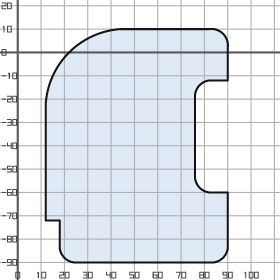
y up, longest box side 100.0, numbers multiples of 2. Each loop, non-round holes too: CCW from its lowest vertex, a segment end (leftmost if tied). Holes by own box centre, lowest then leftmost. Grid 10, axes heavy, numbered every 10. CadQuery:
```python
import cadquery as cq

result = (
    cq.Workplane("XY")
    .moveTo(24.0, -90.0)
    .lineTo(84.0, -90.0)
    .threePointArc((88.0, -88.0), (90.0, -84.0))
    .lineTo(90.0, -60.0)
    .lineTo(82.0, -60.0)
    .threePointArc((78.0, -58.0), (76.0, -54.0))
    .lineTo(76.0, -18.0)
    .threePointArc((78.0, -14.0), (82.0, -12.0))
    .lineTo(90.0, -12.0)
    .lineTo(90.0, 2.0)
    .threePointArc((88.0, 8.0), (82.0, 10.0))
    .lineTo(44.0, 10.0)
    .threePointArc((22.0, 0.0), (12.0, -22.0))
    .lineTo(12.0, -72.0)
    .lineTo(18.0, -72.0)
    .lineTo(18.0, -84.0)
    .threePointArc((20.0, -88.0), (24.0, -90.0))
    .close()
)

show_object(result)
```